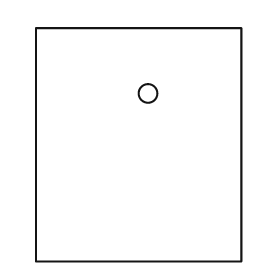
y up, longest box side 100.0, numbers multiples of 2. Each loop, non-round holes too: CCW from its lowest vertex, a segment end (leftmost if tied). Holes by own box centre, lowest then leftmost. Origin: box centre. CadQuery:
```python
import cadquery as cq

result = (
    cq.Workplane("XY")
    .moveTo(-44.0, -50.0)
    .lineTo(44.0, -50.0)
    .lineTo(44.0, 50.0)
    .lineTo(-44.0, 50.0)
    .close()
    .moveTo(4.0, 22.0)
    .circle(4.0)
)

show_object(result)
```